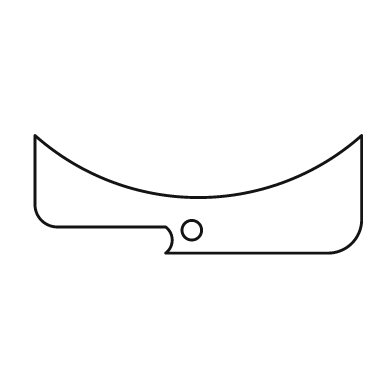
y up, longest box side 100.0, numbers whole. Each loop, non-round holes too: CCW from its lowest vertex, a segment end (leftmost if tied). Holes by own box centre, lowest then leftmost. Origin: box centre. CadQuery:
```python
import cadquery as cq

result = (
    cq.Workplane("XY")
    .moveTo(-10.0, -18.0)
    .lineTo(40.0, -18.0)
    .threePointArc((47.0, -15.0), (50.0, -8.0))
    .lineTo(50.0, 18.0)
    .threePointArc((0.0, -1.0), (-50.0, 18.0))
    .lineTo(-50.0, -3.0)
    .threePointArc((-48.0, -8.0), (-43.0, -10.0))
    .lineTo(-10.0, -10.0)
    .threePointArc((-8.0, -14.0), (-10.0, -18.0))
    .close()
    .moveTo(-2.0, -11.0)
    .circle(3.0)
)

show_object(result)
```